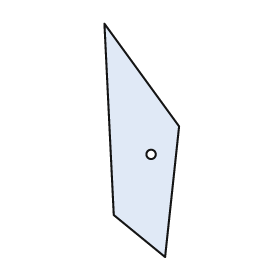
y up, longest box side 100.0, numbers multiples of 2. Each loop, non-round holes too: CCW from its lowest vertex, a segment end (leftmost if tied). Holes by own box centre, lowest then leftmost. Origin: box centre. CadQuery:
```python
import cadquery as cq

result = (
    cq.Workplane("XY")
    .moveTo(10.0, -50.0)
    .lineTo(16.0, 6.0)
    .lineTo(-16.0, 50.0)
    .lineTo(-12.0, -32.0)
    .close()
    .moveTo(4.0, -6.0)
    .circle(2.0)
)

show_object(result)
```